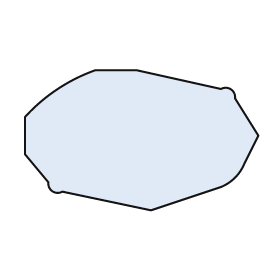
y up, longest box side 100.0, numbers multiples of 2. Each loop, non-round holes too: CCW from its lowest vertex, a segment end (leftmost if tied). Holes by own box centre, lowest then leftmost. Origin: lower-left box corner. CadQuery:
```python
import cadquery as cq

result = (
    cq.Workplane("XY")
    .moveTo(54.0, 0.0)
    .lineTo(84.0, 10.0)
    .threePointArc((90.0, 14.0), (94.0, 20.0))
    .lineTo(100.0, 32.0)
    .lineTo(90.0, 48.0)
    .threePointArc((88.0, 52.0), (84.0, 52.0))
    .lineTo(48.0, 60.0)
    .lineTo(30.0, 60.0)
    .threePointArc((14.0, 52.0), (0.0, 40.0))
    .lineTo(0.0, 24.0)
    .lineTo(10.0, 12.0)
    .threePointArc((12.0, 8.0), (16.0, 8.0))
    .close()
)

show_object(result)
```